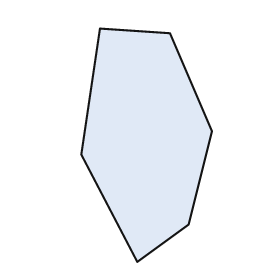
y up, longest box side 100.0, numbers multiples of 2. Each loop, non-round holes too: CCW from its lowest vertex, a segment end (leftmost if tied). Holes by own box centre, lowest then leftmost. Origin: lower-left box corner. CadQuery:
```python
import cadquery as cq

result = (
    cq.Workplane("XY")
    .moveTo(24.0, 0.0)
    .lineTo(46.0, 16.0)
    .lineTo(56.0, 56.0)
    .lineTo(38.0, 98.0)
    .lineTo(8.0, 100.0)
    .lineTo(0.0, 46.0)
    .close()
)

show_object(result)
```